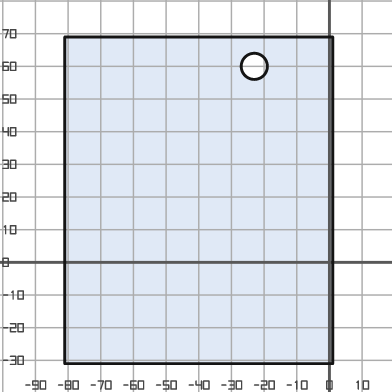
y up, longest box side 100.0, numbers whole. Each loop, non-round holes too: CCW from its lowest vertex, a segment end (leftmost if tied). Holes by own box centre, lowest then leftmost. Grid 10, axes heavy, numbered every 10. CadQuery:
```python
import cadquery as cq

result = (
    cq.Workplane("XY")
    .moveTo(-81.0, -31.0)
    .lineTo(1.0, -31.0)
    .lineTo(1.0, 69.0)
    .lineTo(-81.0, 69.0)
    .close()
    .moveTo(-23.0, 60.0)
    .circle(4.0)
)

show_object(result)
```